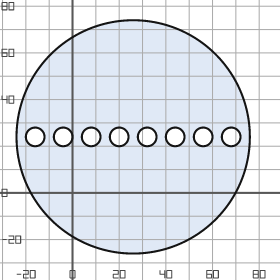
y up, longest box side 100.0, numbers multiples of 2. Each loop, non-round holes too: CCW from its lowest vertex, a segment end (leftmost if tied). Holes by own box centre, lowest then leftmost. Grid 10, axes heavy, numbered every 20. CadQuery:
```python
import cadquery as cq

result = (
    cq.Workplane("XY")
    .moveTo(26.0, 24.0)
    .circle(50.0)
    .moveTo(-16.0, 24.0)
    .circle(4.0)
    .moveTo(-4.0, 24.0)
    .circle(4.0)
    .moveTo(8.0, 24.0)
    .circle(4.0)
    .moveTo(20.0, 24.0)
    .circle(4.0)
    .moveTo(32.0, 24.0)
    .circle(4.0)
    .moveTo(44.0, 24.0)
    .circle(4.0)
    .moveTo(56.0, 24.0)
    .circle(4.0)
    .moveTo(68.0, 24.0)
    .circle(4.0)
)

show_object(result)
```